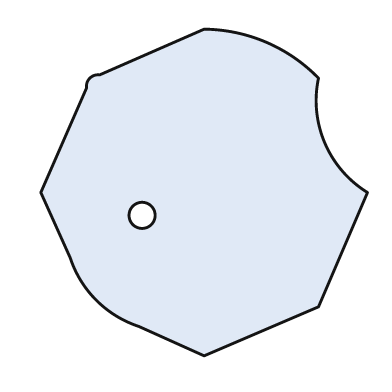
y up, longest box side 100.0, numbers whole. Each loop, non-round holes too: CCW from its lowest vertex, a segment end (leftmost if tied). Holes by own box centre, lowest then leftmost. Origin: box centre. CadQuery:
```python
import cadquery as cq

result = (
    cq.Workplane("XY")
    .moveTo(0.0, -50.0)
    .lineTo(35.0, -35.0)
    .lineTo(50.0, 0.0)
    .threePointArc((37.0, 15.0), (35.0, 35.0))
    .threePointArc((19.0, 46.0), (0.0, 50.0))
    .lineTo(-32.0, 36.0)
    .threePointArc((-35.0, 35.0), (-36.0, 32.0))
    .lineTo(-50.0, 0.0)
    .lineTo(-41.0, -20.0)
    .threePointArc((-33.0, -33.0), (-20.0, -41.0))
    .close()
    .moveTo(-19.0, -7.0)
    .circle(4.0)
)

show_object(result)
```